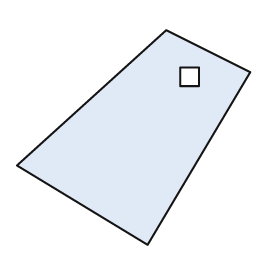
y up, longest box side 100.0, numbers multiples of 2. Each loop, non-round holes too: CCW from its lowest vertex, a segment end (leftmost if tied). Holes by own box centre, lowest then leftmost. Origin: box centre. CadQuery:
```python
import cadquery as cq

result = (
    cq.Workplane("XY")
    .moveTo(6.0, -46.0)
    .lineTo(50.0, 28.0)
    .lineTo(14.0, 46.0)
    .lineTo(-50.0, -12.0)
    .close()
    .moveTo(20.0, 22.0)
    .lineTo(28.0, 22.0)
    .lineTo(28.0, 30.0)
    .lineTo(20.0, 30.0)
    .close()
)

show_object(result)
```